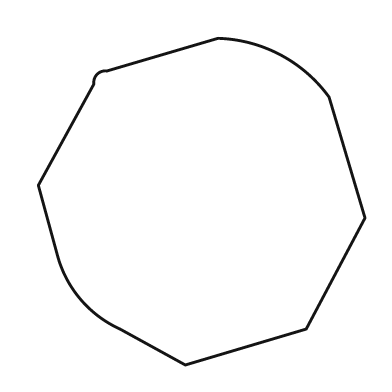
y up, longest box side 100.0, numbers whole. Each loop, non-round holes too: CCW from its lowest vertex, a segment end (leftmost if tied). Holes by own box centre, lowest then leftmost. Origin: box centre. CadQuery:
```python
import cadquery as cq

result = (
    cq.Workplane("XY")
    .moveTo(-5.0, -50.0)
    .lineTo(32.0, -39.0)
    .lineTo(50.0, -5.0)
    .lineTo(39.0, 32.0)
    .threePointArc((24.0, 45.0), (5.0, 50.0))
    .lineTo(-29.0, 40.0)
    .threePointArc((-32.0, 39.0), (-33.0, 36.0))
    .lineTo(-50.0, 5.0)
    .lineTo(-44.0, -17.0)
    .threePointArc((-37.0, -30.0), (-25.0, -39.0))
    .close()
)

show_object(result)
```